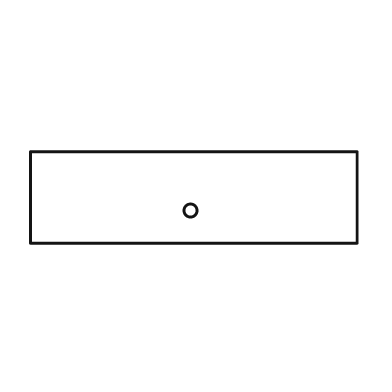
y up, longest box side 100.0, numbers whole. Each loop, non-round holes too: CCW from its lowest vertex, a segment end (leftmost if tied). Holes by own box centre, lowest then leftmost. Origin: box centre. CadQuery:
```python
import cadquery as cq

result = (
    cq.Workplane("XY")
    .moveTo(-50.0, -14.0)
    .lineTo(50.0, -14.0)
    .lineTo(50.0, 14.0)
    .lineTo(-50.0, 14.0)
    .close()
    .moveTo(-1.0, -4.0)
    .circle(2.0)
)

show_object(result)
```